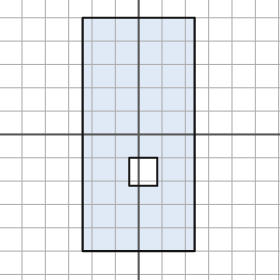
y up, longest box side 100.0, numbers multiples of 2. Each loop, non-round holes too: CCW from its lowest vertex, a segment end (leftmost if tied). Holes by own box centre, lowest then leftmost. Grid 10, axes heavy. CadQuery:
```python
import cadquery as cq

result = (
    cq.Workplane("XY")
    .moveTo(-24.0, -50.0)
    .lineTo(24.0, -50.0)
    .lineTo(24.0, 50.0)
    .lineTo(-24.0, 50.0)
    .close()
    .moveTo(-4.0, -22.0)
    .lineTo(8.0, -22.0)
    .lineTo(8.0, -10.0)
    .lineTo(-4.0, -10.0)
    .close()
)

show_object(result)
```